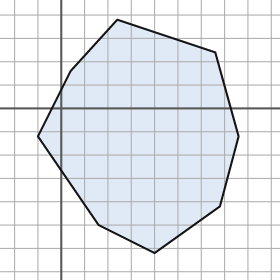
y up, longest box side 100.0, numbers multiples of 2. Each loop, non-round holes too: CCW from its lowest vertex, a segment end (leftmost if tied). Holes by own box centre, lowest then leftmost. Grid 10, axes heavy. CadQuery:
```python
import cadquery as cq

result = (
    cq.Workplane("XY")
    .moveTo(40.0, -62.0)
    .lineTo(68.0, -42.0)
    .lineTo(76.0, -12.0)
    .lineTo(66.0, 24.0)
    .lineTo(24.0, 38.0)
    .lineTo(4.0, 16.0)
    .lineTo(-10.0, -12.0)
    .lineTo(16.0, -50.0)
    .close()
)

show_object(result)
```